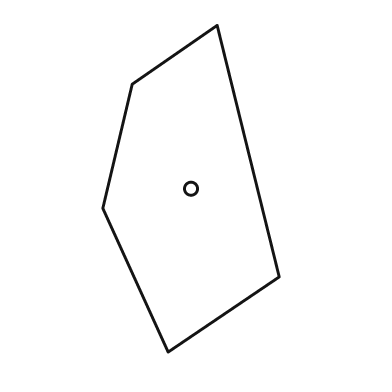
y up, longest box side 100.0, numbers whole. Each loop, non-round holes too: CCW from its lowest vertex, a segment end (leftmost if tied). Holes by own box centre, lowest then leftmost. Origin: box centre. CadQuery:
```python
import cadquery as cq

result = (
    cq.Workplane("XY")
    .moveTo(-7.0, -50.0)
    .lineTo(27.0, -27.0)
    .lineTo(8.0, 50.0)
    .lineTo(-18.0, 32.0)
    .lineTo(-27.0, -6.0)
    .close()
    .moveTo(0.0, 0.0)
    .circle(2.0)
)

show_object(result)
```